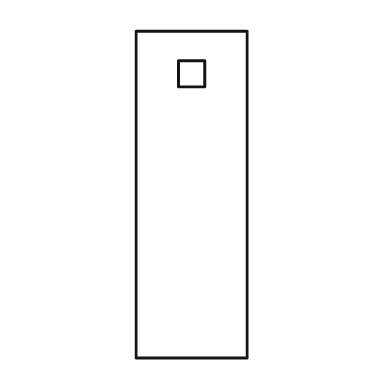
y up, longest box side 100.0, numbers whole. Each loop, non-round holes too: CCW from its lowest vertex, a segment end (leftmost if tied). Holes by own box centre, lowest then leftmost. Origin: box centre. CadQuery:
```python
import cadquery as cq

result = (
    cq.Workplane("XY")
    .moveTo(-17.0, -50.0)
    .lineTo(17.0, -50.0)
    .lineTo(17.0, 50.0)
    .lineTo(-17.0, 50.0)
    .close()
    .moveTo(-4.0, 33.0)
    .lineTo(4.0, 33.0)
    .lineTo(4.0, 41.0)
    .lineTo(-4.0, 41.0)
    .close()
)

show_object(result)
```